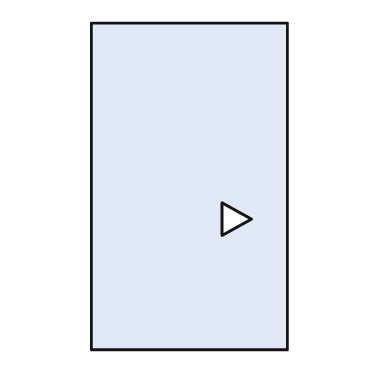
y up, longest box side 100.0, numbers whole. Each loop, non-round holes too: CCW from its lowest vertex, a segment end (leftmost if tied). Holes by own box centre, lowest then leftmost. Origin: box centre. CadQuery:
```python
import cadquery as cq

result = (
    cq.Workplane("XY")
    .moveTo(-30.0, -50.0)
    .lineTo(30.0, -50.0)
    .lineTo(30.0, 50.0)
    .lineTo(-30.0, 50.0)
    .close()
    .moveTo(10.0, -15.0)
    .lineTo(19.0, -10.0)
    .lineTo(10.0, -5.0)
    .close()
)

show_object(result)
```